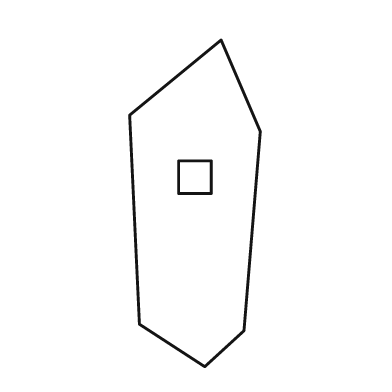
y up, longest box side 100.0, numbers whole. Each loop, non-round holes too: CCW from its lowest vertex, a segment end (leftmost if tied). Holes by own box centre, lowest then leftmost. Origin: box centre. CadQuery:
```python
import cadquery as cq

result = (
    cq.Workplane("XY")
    .moveTo(3.0, -50.0)
    .lineTo(15.0, -39.0)
    .lineTo(20.0, 22.0)
    .lineTo(8.0, 50.0)
    .lineTo(-20.0, 27.0)
    .lineTo(-17.0, -37.0)
    .close()
    .moveTo(-5.0, 3.0)
    .lineTo(5.0, 3.0)
    .lineTo(5.0, 13.0)
    .lineTo(-5.0, 13.0)
    .close()
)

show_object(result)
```